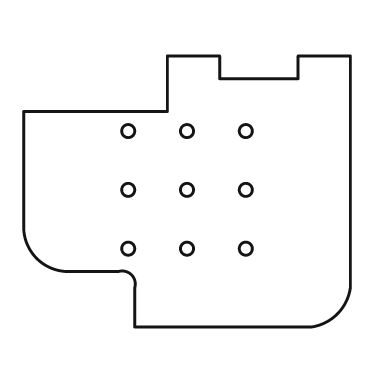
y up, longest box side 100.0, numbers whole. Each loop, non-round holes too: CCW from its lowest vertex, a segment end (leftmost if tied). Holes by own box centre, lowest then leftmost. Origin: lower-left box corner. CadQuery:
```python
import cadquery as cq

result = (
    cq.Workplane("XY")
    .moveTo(34.0, 0.0)
    .lineTo(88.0, 0.0)
    .threePointArc((96.0, 4.0), (100.0, 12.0))
    .lineTo(100.0, 83.0)
    .lineTo(84.0, 83.0)
    .lineTo(84.0, 76.0)
    .lineTo(60.0, 76.0)
    .lineTo(60.0, 83.0)
    .lineTo(44.0, 83.0)
    .lineTo(44.0, 66.0)
    .lineTo(0.0, 66.0)
    .lineTo(0.0, 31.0)
    .threePointArc((4.0, 21.0), (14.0, 17.0))
    .lineTo(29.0, 17.0)
    .threePointArc((33.0, 16.0), (34.0, 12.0))
    .close()
    .moveTo(32.0, 24.0)
    .circle(2.0)
    .moveTo(50.0, 24.0)
    .circle(2.0)
    .moveTo(68.0, 24.0)
    .circle(2.0)
    .moveTo(32.0, 42.0)
    .circle(2.0)
    .moveTo(50.0, 42.0)
    .circle(2.0)
    .moveTo(68.0, 42.0)
    .circle(2.0)
    .moveTo(32.0, 60.0)
    .circle(2.0)
    .moveTo(50.0, 60.0)
    .circle(2.0)
    .moveTo(68.0, 60.0)
    .circle(2.0)
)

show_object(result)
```